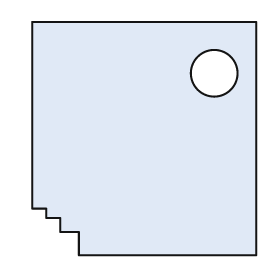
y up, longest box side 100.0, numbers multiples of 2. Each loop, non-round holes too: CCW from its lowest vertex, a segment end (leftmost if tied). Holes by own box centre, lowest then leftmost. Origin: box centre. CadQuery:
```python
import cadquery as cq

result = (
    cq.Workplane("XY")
    .moveTo(-28.0, -50.0)
    .lineTo(48.0, -50.0)
    .lineTo(48.0, 50.0)
    .lineTo(-48.0, 50.0)
    .lineTo(-48.0, -30.0)
    .lineTo(-42.0, -30.0)
    .lineTo(-42.0, -34.0)
    .lineTo(-36.0, -34.0)
    .lineTo(-36.0, -40.0)
    .lineTo(-28.0, -40.0)
    .close()
    .moveTo(30.0, 28.0)
    .circle(10.0)
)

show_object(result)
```